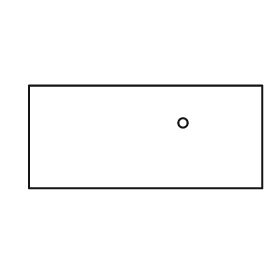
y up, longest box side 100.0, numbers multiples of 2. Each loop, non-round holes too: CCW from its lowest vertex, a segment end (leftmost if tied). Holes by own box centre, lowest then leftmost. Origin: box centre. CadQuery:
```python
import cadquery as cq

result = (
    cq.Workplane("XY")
    .moveTo(-50.0, -22.0)
    .lineTo(50.0, -22.0)
    .lineTo(50.0, 22.0)
    .lineTo(-50.0, 22.0)
    .close()
    .moveTo(16.0, 6.0)
    .circle(2.0)
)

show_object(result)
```